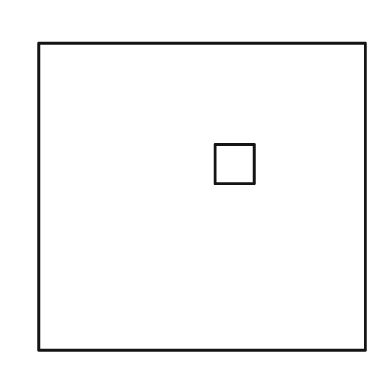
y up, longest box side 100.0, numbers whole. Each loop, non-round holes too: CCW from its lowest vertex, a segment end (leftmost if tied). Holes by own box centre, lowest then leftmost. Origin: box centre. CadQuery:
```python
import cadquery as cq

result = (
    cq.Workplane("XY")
    .moveTo(-50.0, -47.0)
    .lineTo(50.0, -47.0)
    .lineTo(50.0, 47.0)
    .lineTo(-50.0, 47.0)
    .close()
    .moveTo(4.0, 4.0)
    .lineTo(16.0, 4.0)
    .lineTo(16.0, 16.0)
    .lineTo(4.0, 16.0)
    .close()
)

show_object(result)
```